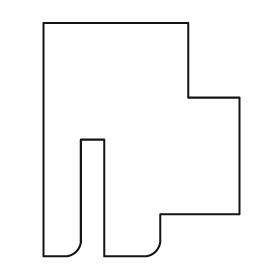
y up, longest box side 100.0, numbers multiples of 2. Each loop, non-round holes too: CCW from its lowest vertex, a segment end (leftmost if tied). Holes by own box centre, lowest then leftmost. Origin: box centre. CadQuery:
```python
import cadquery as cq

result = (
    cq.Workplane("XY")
    .moveTo(-42.0, -50.0)
    .lineTo(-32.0, -50.0)
    .threePointArc((-28.0, -48.0), (-26.0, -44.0))
    .lineTo(-26.0, 0.0)
    .lineTo(-16.0, 0.0)
    .lineTo(-16.0, -50.0)
    .lineTo(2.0, -50.0)
    .threePointArc((6.0, -48.0), (8.0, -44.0))
    .lineTo(8.0, -32.0)
    .lineTo(42.0, -32.0)
    .lineTo(42.0, 18.0)
    .lineTo(20.0, 18.0)
    .lineTo(20.0, 50.0)
    .lineTo(-42.0, 50.0)
    .close()
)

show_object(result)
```